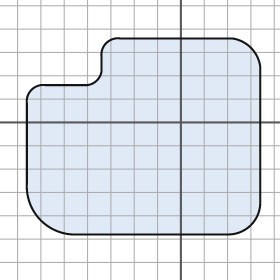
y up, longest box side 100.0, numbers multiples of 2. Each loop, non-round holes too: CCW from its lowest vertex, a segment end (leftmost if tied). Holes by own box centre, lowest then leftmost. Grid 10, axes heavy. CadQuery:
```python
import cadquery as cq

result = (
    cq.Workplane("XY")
    .moveTo(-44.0, -48.0)
    .lineTo(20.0, -48.0)
    .threePointArc((30.0, -44.0), (34.0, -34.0))
    .lineTo(34.0, 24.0)
    .threePointArc((30.0, 32.0), (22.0, 36.0))
    .lineTo(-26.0, 36.0)
    .threePointArc((-32.0, 34.0), (-34.0, 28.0))
    .lineTo(-34.0, 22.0)
    .threePointArc((-36.0, 18.0), (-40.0, 16.0))
    .lineTo(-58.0, 16.0)
    .threePointArc((-64.0, 14.0), (-66.0, 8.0))
    .lineTo(-66.0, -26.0)
    .threePointArc((-60.0, -42.0), (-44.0, -48.0))
    .close()
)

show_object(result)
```